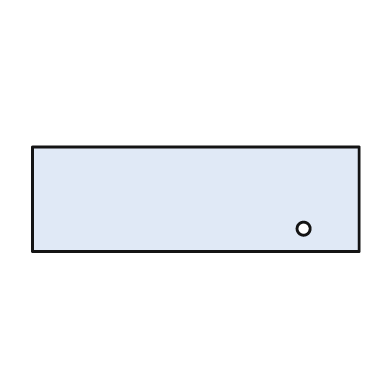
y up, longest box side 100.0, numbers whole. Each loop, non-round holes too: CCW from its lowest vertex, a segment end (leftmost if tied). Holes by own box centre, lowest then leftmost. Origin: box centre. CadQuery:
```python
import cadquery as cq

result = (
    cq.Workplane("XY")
    .moveTo(-50.0, -16.0)
    .lineTo(50.0, -16.0)
    .lineTo(50.0, 16.0)
    .lineTo(-50.0, 16.0)
    .close()
    .moveTo(33.0, -9.0)
    .circle(2.0)
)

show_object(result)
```